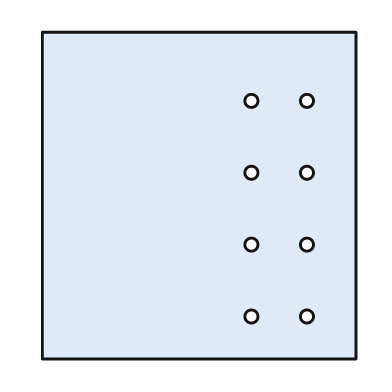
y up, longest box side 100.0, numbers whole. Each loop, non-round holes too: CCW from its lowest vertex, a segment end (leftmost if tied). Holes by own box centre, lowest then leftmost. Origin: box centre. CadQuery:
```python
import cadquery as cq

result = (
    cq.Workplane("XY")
    .moveTo(-48.0, -50.0)
    .lineTo(48.0, -50.0)
    .lineTo(48.0, 50.0)
    .lineTo(-48.0, 50.0)
    .close()
    .moveTo(16.0, -37.0)
    .circle(2.0)
    .moveTo(33.0, -37.0)
    .circle(2.0)
    .moveTo(16.0, -15.0)
    .circle(2.0)
    .moveTo(33.0, -15.0)
    .circle(2.0)
    .moveTo(16.0, 7.0)
    .circle(2.0)
    .moveTo(33.0, 7.0)
    .circle(2.0)
    .moveTo(16.0, 29.0)
    .circle(2.0)
    .moveTo(33.0, 29.0)
    .circle(2.0)
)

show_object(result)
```